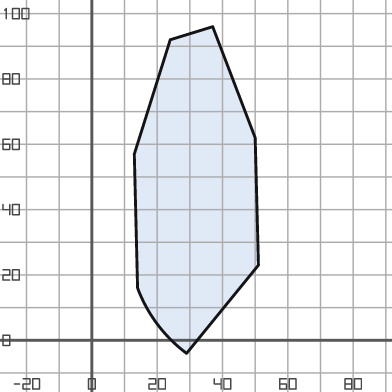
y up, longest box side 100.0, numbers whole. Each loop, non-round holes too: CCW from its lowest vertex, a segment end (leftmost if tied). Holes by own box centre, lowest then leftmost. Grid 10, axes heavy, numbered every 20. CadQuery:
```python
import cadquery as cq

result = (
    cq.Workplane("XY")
    .moveTo(29.0, -4.0)
    .lineTo(51.0, 23.0)
    .lineTo(50.0, 62.0)
    .lineTo(37.0, 96.0)
    .lineTo(24.0, 92.0)
    .lineTo(13.0, 57.0)
    .lineTo(14.0, 16.0)
    .threePointArc((20.0, 5.0), (29.0, -4.0))
    .close()
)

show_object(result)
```